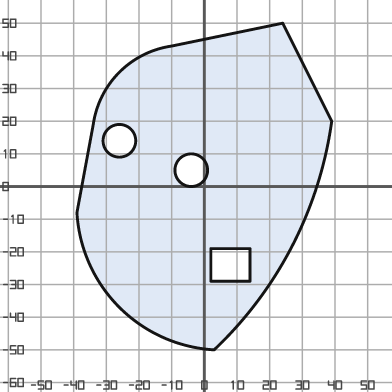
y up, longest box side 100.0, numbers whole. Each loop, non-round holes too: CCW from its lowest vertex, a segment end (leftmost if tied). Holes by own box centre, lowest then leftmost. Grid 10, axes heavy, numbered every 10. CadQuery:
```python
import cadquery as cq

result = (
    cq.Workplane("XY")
    .moveTo(3.0, -50.0)
    .threePointArc((27.0, -18.0), (39.0, 20.0))
    .lineTo(24.0, 50.0)
    .lineTo(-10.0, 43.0)
    .threePointArc((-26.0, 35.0), (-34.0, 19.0))
    .lineTo(-39.0, -8.0)
    .threePointArc((-26.0, -37.0), (3.0, -50.0))
    .close()
    .moveTo(2.0, -29.0)
    .lineTo(14.0, -29.0)
    .lineTo(14.0, -19.0)
    .lineTo(2.0, -19.0)
    .close()
    .moveTo(-4.0, 5.0)
    .circle(5.0)
    .moveTo(-26.0, 14.0)
    .circle(5.0)
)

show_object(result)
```